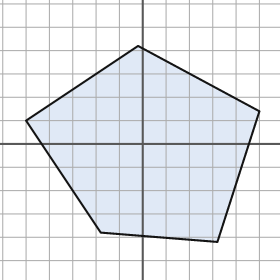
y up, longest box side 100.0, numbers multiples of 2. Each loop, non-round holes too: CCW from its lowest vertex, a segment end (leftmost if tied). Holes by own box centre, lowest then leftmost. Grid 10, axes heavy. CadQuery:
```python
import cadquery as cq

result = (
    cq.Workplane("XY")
    .moveTo(32.0, -42.0)
    .lineTo(50.0, 14.0)
    .lineTo(-2.0, 42.0)
    .lineTo(-50.0, 10.0)
    .lineTo(-18.0, -38.0)
    .close()
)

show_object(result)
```